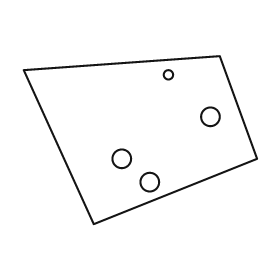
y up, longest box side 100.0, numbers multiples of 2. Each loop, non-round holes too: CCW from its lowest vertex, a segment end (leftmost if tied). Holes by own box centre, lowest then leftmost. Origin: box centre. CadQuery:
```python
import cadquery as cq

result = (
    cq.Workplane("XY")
    .moveTo(-20.0, -36.0)
    .lineTo(50.0, -8.0)
    .lineTo(34.0, 36.0)
    .lineTo(-50.0, 30.0)
    .close()
    .moveTo(4.0, -18.0)
    .circle(4.0)
    .moveTo(-8.0, -8.0)
    .circle(4.0)
    .moveTo(30.0, 10.0)
    .circle(4.0)
    .moveTo(12.0, 28.0)
    .circle(2.0)
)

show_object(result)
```